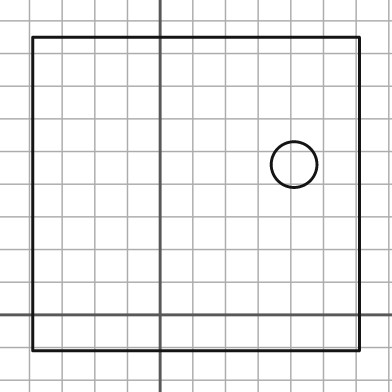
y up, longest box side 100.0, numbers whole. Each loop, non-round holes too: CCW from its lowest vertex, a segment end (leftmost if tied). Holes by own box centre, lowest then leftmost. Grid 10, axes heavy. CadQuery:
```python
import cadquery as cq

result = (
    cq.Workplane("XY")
    .moveTo(-39.0, -11.0)
    .lineTo(61.0, -11.0)
    .lineTo(61.0, 85.0)
    .lineTo(-39.0, 85.0)
    .close()
    .moveTo(41.0, 46.0)
    .circle(7.0)
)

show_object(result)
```